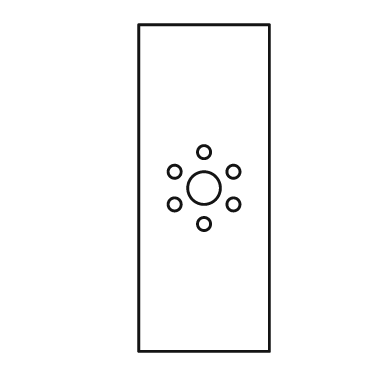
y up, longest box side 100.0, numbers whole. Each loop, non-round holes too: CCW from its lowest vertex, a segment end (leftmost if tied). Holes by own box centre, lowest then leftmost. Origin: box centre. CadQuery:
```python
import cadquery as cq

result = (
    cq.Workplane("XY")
    .moveTo(-20.0, -50.0)
    .lineTo(20.0, -50.0)
    .lineTo(20.0, 50.0)
    .lineTo(-20.0, 50.0)
    .close()
    .moveTo(0.0, -11.0)
    .circle(2.0)
    .moveTo(-9.0, -5.0)
    .circle(2.0)
    .moveTo(9.0, -5.0)
    .circle(2.0)
    .moveTo(0.0, 0.0)
    .circle(5.0)
    .moveTo(-9.0, 5.0)
    .circle(2.0)
    .moveTo(9.0, 5.0)
    .circle(2.0)
    .moveTo(0.0, 11.0)
    .circle(2.0)
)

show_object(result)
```